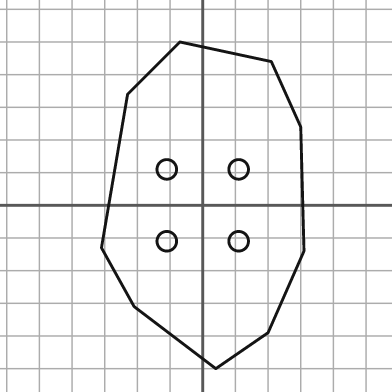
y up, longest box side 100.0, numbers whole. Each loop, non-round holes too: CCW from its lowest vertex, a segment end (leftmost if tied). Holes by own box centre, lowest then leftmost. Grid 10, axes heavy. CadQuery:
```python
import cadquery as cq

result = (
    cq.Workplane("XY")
    .moveTo(4.0, -50.0)
    .lineTo(20.0, -39.0)
    .lineTo(31.0, -14.0)
    .lineTo(30.0, 24.0)
    .lineTo(21.0, 44.0)
    .lineTo(-7.0, 50.0)
    .lineTo(-23.0, 34.0)
    .lineTo(-31.0, -13.0)
    .lineTo(-21.0, -31.0)
    .close()
    .moveTo(-11.0, -11.0)
    .circle(3.0)
    .moveTo(11.0, -11.0)
    .circle(3.0)
    .moveTo(-11.0, 11.0)
    .circle(3.0)
    .moveTo(11.0, 11.0)
    .circle(3.0)
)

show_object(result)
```